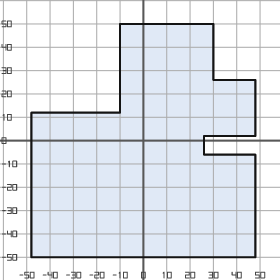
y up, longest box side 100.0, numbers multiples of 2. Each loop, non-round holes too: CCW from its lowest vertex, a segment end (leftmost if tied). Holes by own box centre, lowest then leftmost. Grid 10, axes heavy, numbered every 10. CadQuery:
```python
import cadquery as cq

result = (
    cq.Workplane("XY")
    .moveTo(-48.0, -50.0)
    .lineTo(48.0, -50.0)
    .lineTo(48.0, -6.0)
    .lineTo(26.0, -6.0)
    .lineTo(26.0, 2.0)
    .lineTo(48.0, 2.0)
    .lineTo(48.0, 26.0)
    .lineTo(30.0, 26.0)
    .lineTo(30.0, 50.0)
    .lineTo(-10.0, 50.0)
    .lineTo(-10.0, 12.0)
    .lineTo(-48.0, 12.0)
    .close()
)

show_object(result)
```